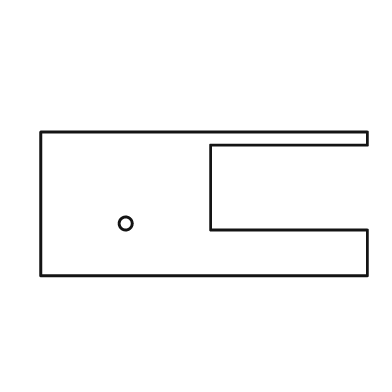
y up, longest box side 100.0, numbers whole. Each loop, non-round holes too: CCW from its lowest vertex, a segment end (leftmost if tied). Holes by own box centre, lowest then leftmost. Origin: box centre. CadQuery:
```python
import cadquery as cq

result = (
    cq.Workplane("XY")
    .moveTo(-50.0, -22.0)
    .lineTo(50.0, -22.0)
    .lineTo(50.0, -8.0)
    .lineTo(2.0, -8.0)
    .lineTo(2.0, 18.0)
    .lineTo(50.0, 18.0)
    .lineTo(50.0, 22.0)
    .lineTo(-50.0, 22.0)
    .close()
    .moveTo(-24.0, -6.0)
    .circle(2.0)
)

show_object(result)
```